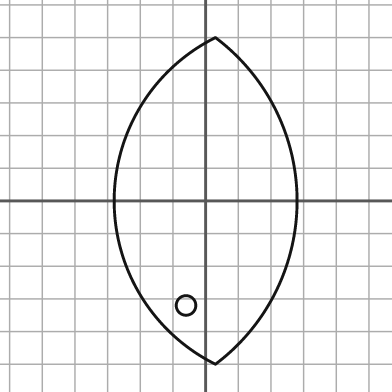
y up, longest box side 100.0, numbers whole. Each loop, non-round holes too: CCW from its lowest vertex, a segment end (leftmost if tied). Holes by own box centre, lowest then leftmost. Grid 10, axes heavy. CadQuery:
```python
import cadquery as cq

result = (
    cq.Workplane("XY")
    .moveTo(3.0, -50.0)
    .threePointArc((28.0, 0.0), (3.0, 50.0))
    .threePointArc((-28.0, 0.0), (3.0, -50.0))
    .close()
    .moveTo(-6.0, -32.0)
    .circle(3.0)
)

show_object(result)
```